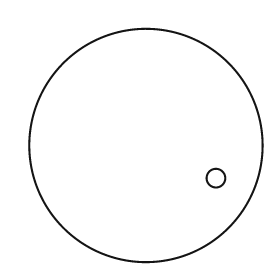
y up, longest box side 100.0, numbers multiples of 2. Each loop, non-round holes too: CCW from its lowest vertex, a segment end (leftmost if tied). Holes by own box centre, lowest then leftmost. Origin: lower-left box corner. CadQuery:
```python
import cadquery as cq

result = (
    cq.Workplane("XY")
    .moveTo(50.0, 50.0)
    .circle(50.0)
    .moveTo(80.0, 36.0)
    .circle(4.0)
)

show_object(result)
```